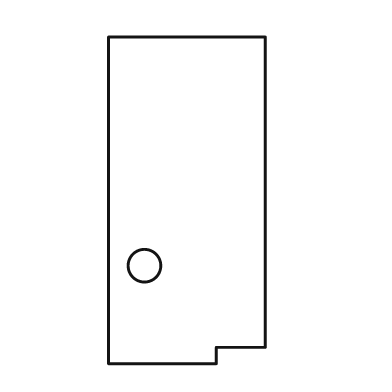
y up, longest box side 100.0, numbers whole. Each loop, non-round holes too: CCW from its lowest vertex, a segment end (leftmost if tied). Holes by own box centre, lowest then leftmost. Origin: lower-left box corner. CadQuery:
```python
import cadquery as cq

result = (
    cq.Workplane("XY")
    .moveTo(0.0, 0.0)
    .lineTo(33.0, 0.0)
    .lineTo(33.0, 5.0)
    .lineTo(48.0, 5.0)
    .lineTo(48.0, 100.0)
    .lineTo(0.0, 100.0)
    .close()
    .moveTo(11.0, 30.0)
    .circle(5.0)
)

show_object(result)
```